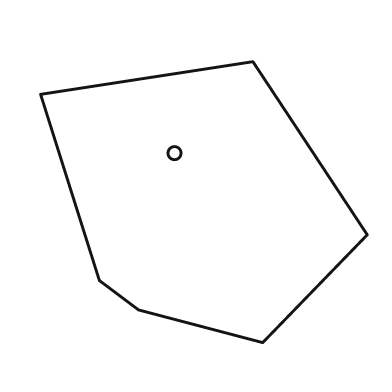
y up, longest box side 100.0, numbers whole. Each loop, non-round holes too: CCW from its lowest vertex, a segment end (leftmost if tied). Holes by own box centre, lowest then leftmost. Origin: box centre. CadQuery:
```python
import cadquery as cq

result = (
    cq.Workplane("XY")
    .moveTo(18.0, -43.0)
    .lineTo(50.0, -10.0)
    .lineTo(15.0, 43.0)
    .lineTo(-50.0, 33.0)
    .lineTo(-32.0, -24.0)
    .lineTo(-20.0, -33.0)
    .close()
    .moveTo(-9.0, 15.0)
    .circle(2.0)
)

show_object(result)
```